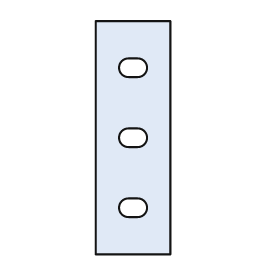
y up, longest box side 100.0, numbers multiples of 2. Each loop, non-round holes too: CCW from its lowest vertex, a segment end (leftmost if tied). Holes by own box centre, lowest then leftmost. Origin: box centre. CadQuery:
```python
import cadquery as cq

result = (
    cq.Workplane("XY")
    .moveTo(-16.0, -50.0)
    .lineTo(16.0, -50.0)
    .lineTo(16.0, 50.0)
    .lineTo(-16.0, 50.0)
    .close()
    .moveTo(-2.0, -34.0)
    .lineTo(2.0, -34.0)
    .threePointArc((6.0, -30.0), (2.0, -26.0))
    .lineTo(-2.0, -26.0)
    .threePointArc((-6.0, -30.0), (-2.0, -34.0))
    .close()
    .moveTo(-2.0, -4.0)
    .lineTo(2.0, -4.0)
    .threePointArc((6.0, 0.0), (2.0, 4.0))
    .lineTo(-2.0, 4.0)
    .threePointArc((-6.0, 0.0), (-2.0, -4.0))
    .close()
    .moveTo(-2.0, 26.0)
    .lineTo(2.0, 26.0)
    .threePointArc((6.0, 30.0), (2.0, 34.0))
    .lineTo(-2.0, 34.0)
    .threePointArc((-6.0, 30.0), (-2.0, 26.0))
    .close()
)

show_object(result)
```